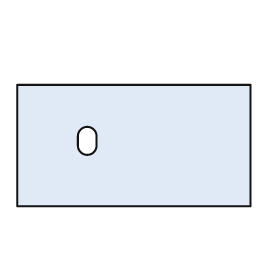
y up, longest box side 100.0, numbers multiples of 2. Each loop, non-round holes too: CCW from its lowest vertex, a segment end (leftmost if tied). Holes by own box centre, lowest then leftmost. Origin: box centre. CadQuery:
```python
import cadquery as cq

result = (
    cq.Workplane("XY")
    .moveTo(-50.0, -26.0)
    .lineTo(50.0, -26.0)
    .lineTo(50.0, 26.0)
    .lineTo(-50.0, 26.0)
    .close()
    .moveTo(-24.0, 0.0)
    .threePointArc((-20.0, -4.0), (-16.0, 0.0))
    .lineTo(-16.0, 4.0)
    .threePointArc((-20.0, 8.0), (-24.0, 4.0))
    .close()
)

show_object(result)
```